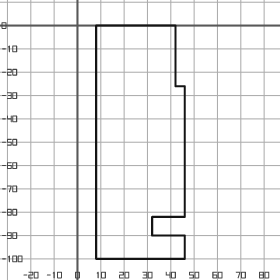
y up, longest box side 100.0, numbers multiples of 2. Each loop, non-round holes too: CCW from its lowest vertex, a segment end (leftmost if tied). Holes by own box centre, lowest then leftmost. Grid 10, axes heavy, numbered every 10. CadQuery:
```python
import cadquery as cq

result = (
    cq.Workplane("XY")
    .moveTo(8.0, -100.0)
    .lineTo(46.0, -100.0)
    .lineTo(46.0, -90.0)
    .lineTo(32.0, -90.0)
    .lineTo(32.0, -82.0)
    .lineTo(46.0, -82.0)
    .lineTo(46.0, -26.0)
    .lineTo(42.0, -26.0)
    .lineTo(42.0, 0.0)
    .lineTo(8.0, 0.0)
    .close()
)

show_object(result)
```